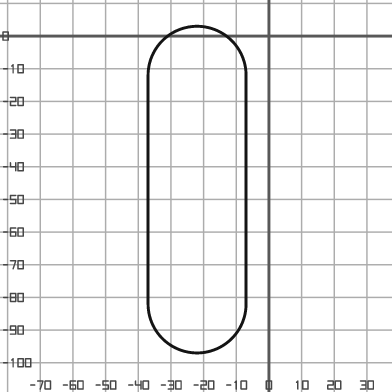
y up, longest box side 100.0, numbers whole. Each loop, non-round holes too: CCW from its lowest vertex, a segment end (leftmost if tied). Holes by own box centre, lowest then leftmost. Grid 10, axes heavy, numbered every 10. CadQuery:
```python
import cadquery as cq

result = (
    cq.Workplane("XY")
    .moveTo(-37.0, -82.0)
    .threePointArc((-22.0, -97.0), (-7.0, -82.0))
    .lineTo(-7.0, -12.0)
    .threePointArc((-22.0, 3.0), (-37.0, -12.0))
    .close()
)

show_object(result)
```